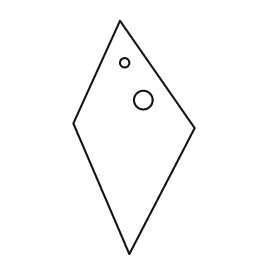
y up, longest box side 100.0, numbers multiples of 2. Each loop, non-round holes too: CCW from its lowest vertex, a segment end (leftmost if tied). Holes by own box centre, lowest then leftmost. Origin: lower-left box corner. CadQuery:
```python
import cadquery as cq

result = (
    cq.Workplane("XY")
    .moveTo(24.0, 0.0)
    .lineTo(52.0, 54.0)
    .lineTo(20.0, 100.0)
    .lineTo(0.0, 56.0)
    .close()
    .moveTo(30.0, 66.0)
    .circle(4.0)
    .moveTo(22.0, 82.0)
    .circle(2.0)
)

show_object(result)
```